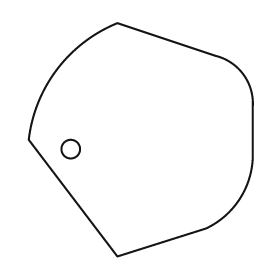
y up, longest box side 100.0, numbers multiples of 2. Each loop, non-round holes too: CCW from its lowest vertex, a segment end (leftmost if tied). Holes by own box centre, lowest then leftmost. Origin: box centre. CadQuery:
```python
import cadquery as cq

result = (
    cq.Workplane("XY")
    .moveTo(-10.0, -50.0)
    .lineTo(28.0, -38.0)
    .threePointArc((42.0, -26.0), (48.0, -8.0))
    .lineTo(48.0, 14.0)
    .threePointArc((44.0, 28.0), (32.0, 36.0))
    .lineTo(-10.0, 50.0)
    .threePointArc((-36.0, 30.0), (-48.0, 0.0))
    .close()
    .moveTo(-30.0, -4.0)
    .circle(4.0)
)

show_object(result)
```